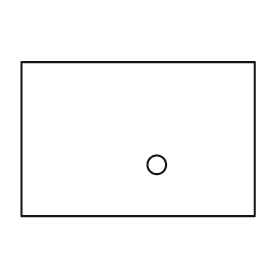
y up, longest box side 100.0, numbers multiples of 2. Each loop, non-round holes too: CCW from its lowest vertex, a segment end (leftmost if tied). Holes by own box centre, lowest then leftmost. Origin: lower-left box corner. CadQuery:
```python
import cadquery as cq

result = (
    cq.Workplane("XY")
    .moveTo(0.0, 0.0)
    .lineTo(100.0, 0.0)
    .lineTo(100.0, 66.0)
    .lineTo(0.0, 66.0)
    .close()
    .moveTo(58.0, 22.0)
    .circle(4.0)
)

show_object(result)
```